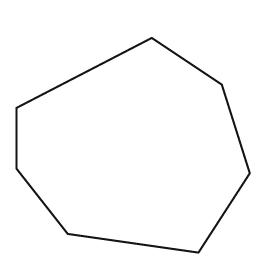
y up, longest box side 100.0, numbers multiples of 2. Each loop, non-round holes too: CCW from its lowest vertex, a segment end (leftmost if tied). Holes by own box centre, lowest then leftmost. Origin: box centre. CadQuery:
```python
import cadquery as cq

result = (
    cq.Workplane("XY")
    .moveTo(28.0, -46.0)
    .lineTo(50.0, -12.0)
    .lineTo(38.0, 26.0)
    .lineTo(8.0, 46.0)
    .lineTo(-50.0, 16.0)
    .lineTo(-50.0, -10.0)
    .lineTo(-28.0, -38.0)
    .close()
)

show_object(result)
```